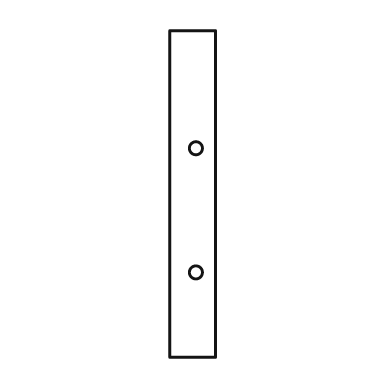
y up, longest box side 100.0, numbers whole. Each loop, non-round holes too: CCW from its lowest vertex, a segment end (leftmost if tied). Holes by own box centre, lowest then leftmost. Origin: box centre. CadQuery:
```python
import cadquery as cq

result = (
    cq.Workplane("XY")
    .moveTo(-7.0, -50.0)
    .lineTo(7.0, -50.0)
    .lineTo(7.0, 50.0)
    .lineTo(-7.0, 50.0)
    .close()
    .moveTo(1.0, -24.0)
    .circle(2.0)
    .moveTo(1.0, 14.0)
    .circle(2.0)
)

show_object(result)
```